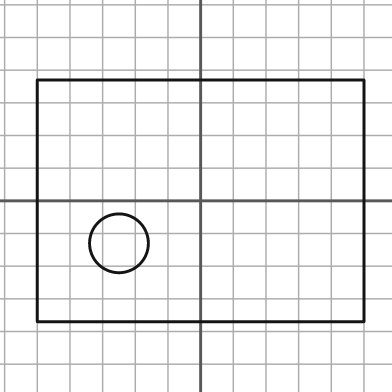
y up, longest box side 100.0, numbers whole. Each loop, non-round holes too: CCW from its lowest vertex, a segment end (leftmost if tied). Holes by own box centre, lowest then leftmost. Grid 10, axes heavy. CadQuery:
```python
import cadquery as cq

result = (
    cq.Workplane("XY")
    .moveTo(-50.0, -37.0)
    .lineTo(50.0, -37.0)
    .lineTo(50.0, 37.0)
    .lineTo(-50.0, 37.0)
    .close()
    .moveTo(-25.0, -13.0)
    .circle(9.0)
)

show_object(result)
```